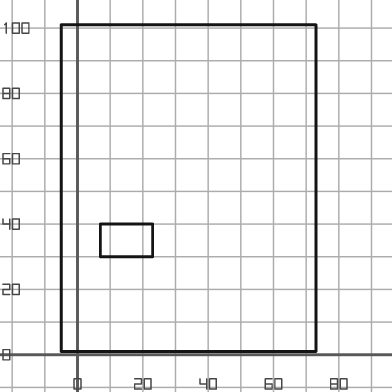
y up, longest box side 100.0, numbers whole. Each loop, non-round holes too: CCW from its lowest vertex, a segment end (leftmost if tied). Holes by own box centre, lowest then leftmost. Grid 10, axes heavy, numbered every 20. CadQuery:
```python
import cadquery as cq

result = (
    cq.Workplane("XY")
    .moveTo(-5.0, 1.0)
    .lineTo(73.0, 1.0)
    .lineTo(73.0, 101.0)
    .lineTo(-5.0, 101.0)
    .close()
    .moveTo(7.0, 30.0)
    .lineTo(23.0, 30.0)
    .lineTo(23.0, 40.0)
    .lineTo(7.0, 40.0)
    .close()
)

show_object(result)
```